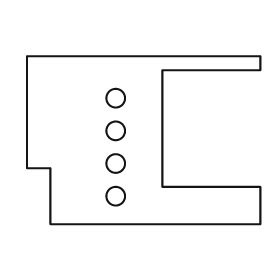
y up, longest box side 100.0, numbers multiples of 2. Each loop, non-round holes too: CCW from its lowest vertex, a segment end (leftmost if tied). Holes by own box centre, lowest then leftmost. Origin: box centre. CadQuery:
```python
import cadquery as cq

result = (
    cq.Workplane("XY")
    .moveTo(-40.0, -36.0)
    .lineTo(50.0, -36.0)
    .lineTo(50.0, -20.0)
    .lineTo(8.0, -20.0)
    .lineTo(8.0, 30.0)
    .lineTo(50.0, 30.0)
    .lineTo(50.0, 36.0)
    .lineTo(-50.0, 36.0)
    .lineTo(-50.0, -12.0)
    .lineTo(-40.0, -12.0)
    .close()
    .moveTo(-12.0, -24.0)
    .circle(4.0)
    .moveTo(-12.0, -10.0)
    .circle(4.0)
    .moveTo(-12.0, 4.0)
    .circle(4.0)
    .moveTo(-12.0, 18.0)
    .circle(4.0)
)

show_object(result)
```